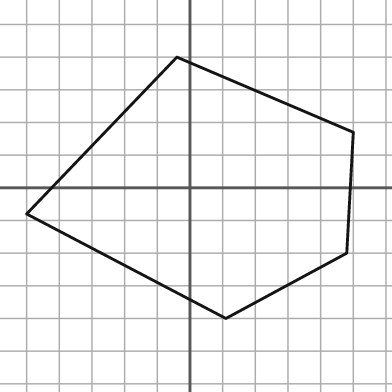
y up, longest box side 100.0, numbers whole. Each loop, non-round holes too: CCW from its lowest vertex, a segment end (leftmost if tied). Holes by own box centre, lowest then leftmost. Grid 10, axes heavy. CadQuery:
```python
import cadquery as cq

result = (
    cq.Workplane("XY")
    .moveTo(11.0, -40.0)
    .lineTo(48.0, -20.0)
    .lineTo(50.0, 17.0)
    .lineTo(-4.0, 40.0)
    .lineTo(-50.0, -8.0)
    .close()
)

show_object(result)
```